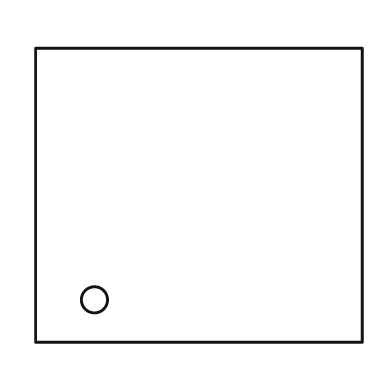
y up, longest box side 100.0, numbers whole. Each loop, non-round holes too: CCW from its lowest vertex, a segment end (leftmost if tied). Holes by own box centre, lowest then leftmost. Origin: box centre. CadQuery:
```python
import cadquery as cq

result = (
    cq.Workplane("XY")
    .moveTo(-50.0, -45.0)
    .lineTo(50.0, -45.0)
    .lineTo(50.0, 45.0)
    .lineTo(-50.0, 45.0)
    .close()
    .moveTo(-32.0, -32.0)
    .circle(4.0)
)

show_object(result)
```